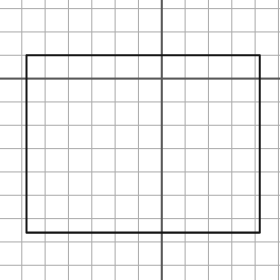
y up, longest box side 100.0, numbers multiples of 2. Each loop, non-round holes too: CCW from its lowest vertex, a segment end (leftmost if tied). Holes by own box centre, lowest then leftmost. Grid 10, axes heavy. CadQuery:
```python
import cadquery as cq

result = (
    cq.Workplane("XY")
    .moveTo(-58.0, -66.0)
    .lineTo(42.0, -66.0)
    .lineTo(42.0, 10.0)
    .lineTo(-58.0, 10.0)
    .close()
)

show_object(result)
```